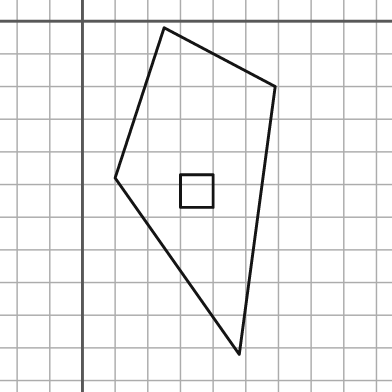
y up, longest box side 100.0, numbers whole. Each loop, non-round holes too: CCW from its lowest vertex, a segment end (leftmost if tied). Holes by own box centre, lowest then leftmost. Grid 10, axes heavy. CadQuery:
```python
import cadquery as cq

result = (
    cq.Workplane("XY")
    .moveTo(48.0, -102.0)
    .lineTo(59.0, -20.0)
    .lineTo(25.0, -2.0)
    .lineTo(10.0, -48.0)
    .close()
    .moveTo(30.0, -57.0)
    .lineTo(40.0, -57.0)
    .lineTo(40.0, -47.0)
    .lineTo(30.0, -47.0)
    .close()
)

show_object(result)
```